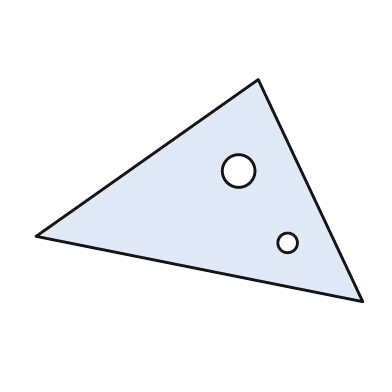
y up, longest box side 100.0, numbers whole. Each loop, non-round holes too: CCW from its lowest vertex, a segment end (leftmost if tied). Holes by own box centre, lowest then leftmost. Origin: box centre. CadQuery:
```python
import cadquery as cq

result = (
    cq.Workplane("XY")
    .moveTo(50.0, -34.0)
    .lineTo(18.0, 34.0)
    .lineTo(-50.0, -14.0)
    .close()
    .moveTo(27.0, -16.0)
    .circle(3.0)
    .moveTo(12.0, 6.0)
    .circle(5.0)
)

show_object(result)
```